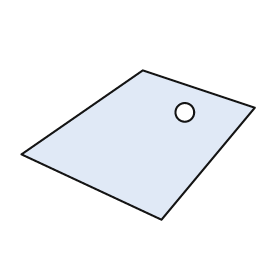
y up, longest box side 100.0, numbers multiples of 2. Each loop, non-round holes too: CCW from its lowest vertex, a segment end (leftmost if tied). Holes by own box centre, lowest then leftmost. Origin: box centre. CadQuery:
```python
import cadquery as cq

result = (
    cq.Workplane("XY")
    .moveTo(10.0, -32.0)
    .lineTo(50.0, 16.0)
    .lineTo(2.0, 32.0)
    .lineTo(-50.0, -4.0)
    .close()
    .moveTo(20.0, 14.0)
    .circle(4.0)
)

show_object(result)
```